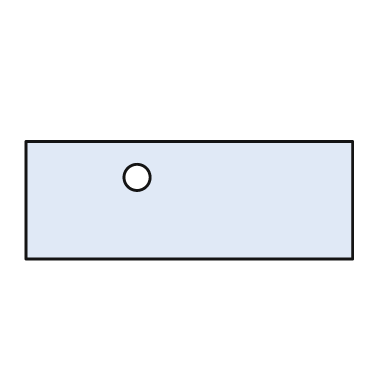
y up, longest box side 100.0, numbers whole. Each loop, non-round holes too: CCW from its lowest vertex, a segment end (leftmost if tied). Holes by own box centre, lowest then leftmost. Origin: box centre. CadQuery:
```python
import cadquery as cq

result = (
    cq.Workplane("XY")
    .moveTo(-50.0, -18.0)
    .lineTo(50.0, -18.0)
    .lineTo(50.0, 18.0)
    .lineTo(-50.0, 18.0)
    .close()
    .moveTo(-16.0, 7.0)
    .circle(4.0)
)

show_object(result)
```